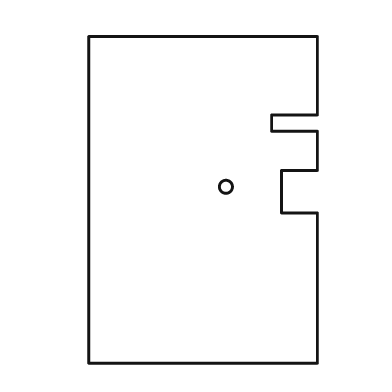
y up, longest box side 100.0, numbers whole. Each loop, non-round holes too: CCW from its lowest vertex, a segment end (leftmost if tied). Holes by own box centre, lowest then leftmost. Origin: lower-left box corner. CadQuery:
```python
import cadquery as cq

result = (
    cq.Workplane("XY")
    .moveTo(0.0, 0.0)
    .lineTo(70.0, 0.0)
    .lineTo(70.0, 46.0)
    .lineTo(59.0, 46.0)
    .lineTo(59.0, 59.0)
    .lineTo(70.0, 59.0)
    .lineTo(70.0, 71.0)
    .lineTo(56.0, 71.0)
    .lineTo(56.0, 76.0)
    .lineTo(70.0, 76.0)
    .lineTo(70.0, 100.0)
    .lineTo(0.0, 100.0)
    .close()
    .moveTo(42.0, 54.0)
    .circle(2.0)
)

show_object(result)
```